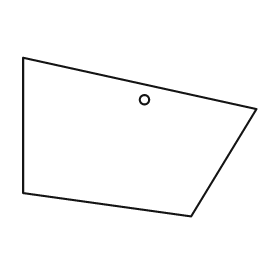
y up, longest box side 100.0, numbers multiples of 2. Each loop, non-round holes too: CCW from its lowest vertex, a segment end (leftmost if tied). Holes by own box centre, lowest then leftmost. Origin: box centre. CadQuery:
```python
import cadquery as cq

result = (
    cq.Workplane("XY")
    .moveTo(22.0, -34.0)
    .lineTo(50.0, 12.0)
    .lineTo(-50.0, 34.0)
    .lineTo(-50.0, -24.0)
    .close()
    .moveTo(2.0, 16.0)
    .circle(2.0)
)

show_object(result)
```